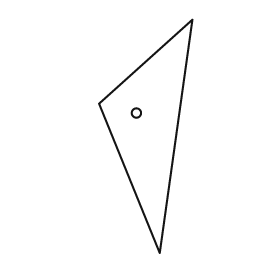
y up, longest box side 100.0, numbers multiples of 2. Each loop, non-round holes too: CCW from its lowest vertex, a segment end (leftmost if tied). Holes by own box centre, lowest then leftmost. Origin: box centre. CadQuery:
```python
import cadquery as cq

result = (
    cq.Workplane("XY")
    .moveTo(6.0, -50.0)
    .lineTo(20.0, 50.0)
    .lineTo(-20.0, 14.0)
    .close()
    .moveTo(-4.0, 10.0)
    .circle(2.0)
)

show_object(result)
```